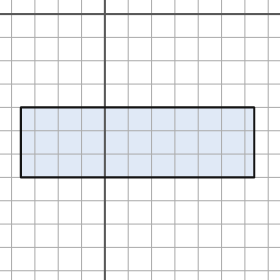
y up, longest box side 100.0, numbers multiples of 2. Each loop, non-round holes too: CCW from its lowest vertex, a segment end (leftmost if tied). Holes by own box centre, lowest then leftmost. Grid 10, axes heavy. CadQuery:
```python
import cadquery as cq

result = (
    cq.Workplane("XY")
    .moveTo(-36.0, -70.0)
    .lineTo(64.0, -70.0)
    .lineTo(64.0, -40.0)
    .lineTo(-36.0, -40.0)
    .close()
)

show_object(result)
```